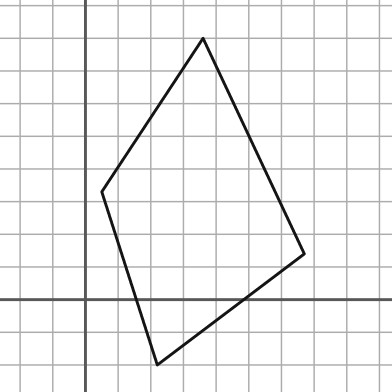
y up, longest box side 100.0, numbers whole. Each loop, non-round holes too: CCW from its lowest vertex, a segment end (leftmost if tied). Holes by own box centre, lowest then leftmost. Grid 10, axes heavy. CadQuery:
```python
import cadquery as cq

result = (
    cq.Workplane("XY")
    .moveTo(22.0, -20.0)
    .lineTo(67.0, 14.0)
    .lineTo(36.0, 80.0)
    .lineTo(5.0, 33.0)
    .close()
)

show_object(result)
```